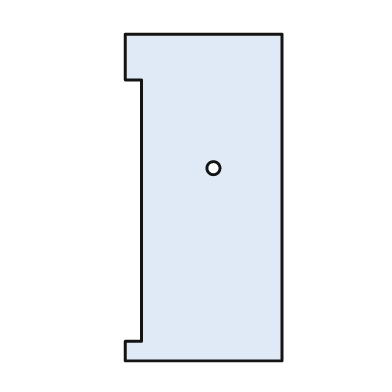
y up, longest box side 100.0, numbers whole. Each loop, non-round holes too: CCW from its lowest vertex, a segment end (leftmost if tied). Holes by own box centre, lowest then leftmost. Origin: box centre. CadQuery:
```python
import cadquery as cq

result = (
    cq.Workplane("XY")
    .moveTo(-24.0, -50.0)
    .lineTo(24.0, -50.0)
    .lineTo(24.0, 50.0)
    .lineTo(-24.0, 50.0)
    .lineTo(-24.0, 36.0)
    .lineTo(-19.0, 36.0)
    .lineTo(-19.0, -44.0)
    .lineTo(-24.0, -44.0)
    .close()
    .moveTo(3.0, 9.0)
    .circle(2.0)
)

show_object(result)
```